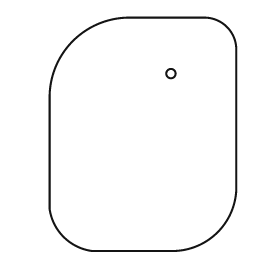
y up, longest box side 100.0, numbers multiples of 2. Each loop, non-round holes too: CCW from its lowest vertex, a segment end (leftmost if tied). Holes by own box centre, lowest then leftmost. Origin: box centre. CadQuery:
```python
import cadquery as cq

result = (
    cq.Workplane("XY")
    .moveTo(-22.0, -50.0)
    .lineTo(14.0, -50.0)
    .threePointArc((32.0, -42.0), (40.0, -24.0))
    .lineTo(40.0, 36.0)
    .threePointArc((36.0, 46.0), (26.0, 50.0))
    .lineTo(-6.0, 50.0)
    .threePointArc((-30.0, 40.0), (-40.0, 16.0))
    .lineTo(-40.0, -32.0)
    .threePointArc((-34.0, -44.0), (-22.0, -50.0))
    .close()
    .moveTo(12.0, 26.0)
    .circle(2.0)
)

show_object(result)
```